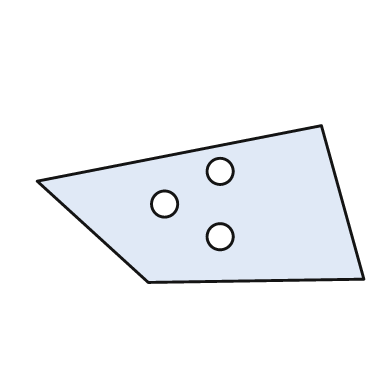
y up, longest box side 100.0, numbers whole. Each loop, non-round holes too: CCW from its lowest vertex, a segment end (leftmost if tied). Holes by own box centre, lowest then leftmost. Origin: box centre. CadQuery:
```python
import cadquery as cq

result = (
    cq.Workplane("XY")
    .moveTo(-16.0, -24.0)
    .lineTo(50.0, -23.0)
    .lineTo(37.0, 24.0)
    .lineTo(-50.0, 7.0)
    .close()
    .moveTo(6.0, -10.0)
    .circle(4.0)
    .moveTo(-11.0, 0.0)
    .circle(4.0)
    .moveTo(6.0, 10.0)
    .circle(4.0)
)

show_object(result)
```